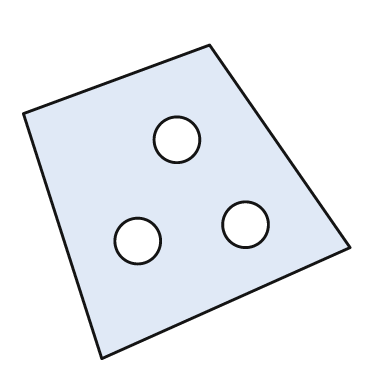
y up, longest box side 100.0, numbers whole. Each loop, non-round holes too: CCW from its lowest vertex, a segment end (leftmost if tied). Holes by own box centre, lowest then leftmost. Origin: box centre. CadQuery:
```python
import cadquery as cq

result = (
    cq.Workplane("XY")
    .moveTo(-26.0, -48.0)
    .lineTo(50.0, -14.0)
    .lineTo(7.0, 48.0)
    .lineTo(-50.0, 27.0)
    .close()
    .moveTo(-15.0, -12.0)
    .circle(7.0)
    .moveTo(18.0, -7.0)
    .circle(7.0)
    .moveTo(-3.0, 19.0)
    .circle(7.0)
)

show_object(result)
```